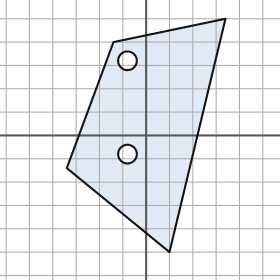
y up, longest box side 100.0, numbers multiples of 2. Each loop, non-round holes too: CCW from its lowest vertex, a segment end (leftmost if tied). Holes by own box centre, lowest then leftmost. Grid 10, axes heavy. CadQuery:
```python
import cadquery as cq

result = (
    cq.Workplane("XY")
    .moveTo(10.0, -50.0)
    .lineTo(34.0, 50.0)
    .lineTo(-14.0, 40.0)
    .lineTo(-34.0, -14.0)
    .close()
    .moveTo(-8.0, -8.0)
    .circle(4.0)
    .moveTo(-8.0, 32.0)
    .circle(4.0)
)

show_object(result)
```